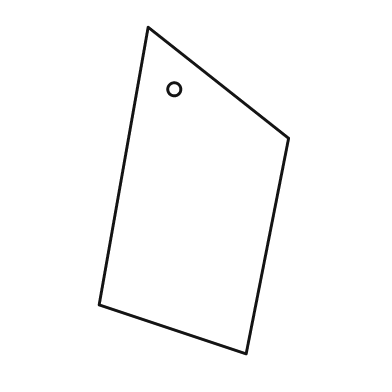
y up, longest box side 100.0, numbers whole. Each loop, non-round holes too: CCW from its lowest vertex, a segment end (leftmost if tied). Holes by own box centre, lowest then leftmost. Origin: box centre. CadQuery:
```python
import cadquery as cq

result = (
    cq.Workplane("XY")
    .moveTo(16.0, -50.0)
    .lineTo(29.0, 16.0)
    .lineTo(-14.0, 50.0)
    .lineTo(-29.0, -35.0)
    .close()
    .moveTo(-6.0, 31.0)
    .circle(2.0)
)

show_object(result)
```